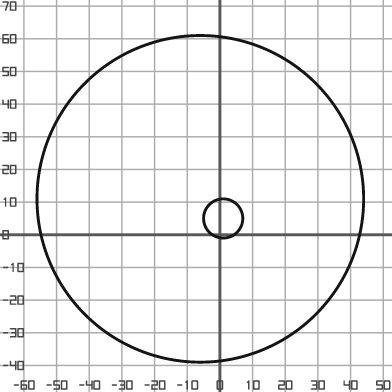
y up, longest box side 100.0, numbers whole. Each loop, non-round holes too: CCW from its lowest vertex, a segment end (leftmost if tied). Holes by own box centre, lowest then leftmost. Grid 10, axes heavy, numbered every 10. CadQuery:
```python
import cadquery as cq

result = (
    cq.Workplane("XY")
    .moveTo(-6.0, 11.0)
    .circle(50.0)
    .moveTo(1.0, 5.0)
    .circle(6.0)
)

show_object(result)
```